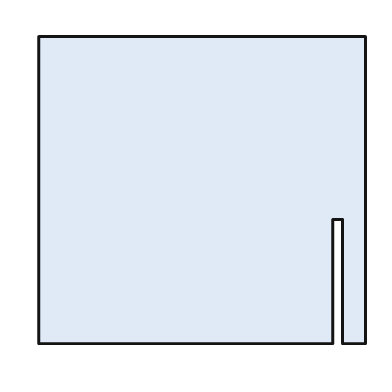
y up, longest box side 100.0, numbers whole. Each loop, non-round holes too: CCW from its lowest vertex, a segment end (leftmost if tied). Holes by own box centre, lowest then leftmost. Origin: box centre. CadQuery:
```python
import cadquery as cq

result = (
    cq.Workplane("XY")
    .moveTo(-50.0, -47.0)
    .lineTo(40.0, -47.0)
    .lineTo(40.0, -9.0)
    .lineTo(43.0, -9.0)
    .lineTo(43.0, -47.0)
    .lineTo(50.0, -47.0)
    .lineTo(50.0, 47.0)
    .lineTo(-50.0, 47.0)
    .close()
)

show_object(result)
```